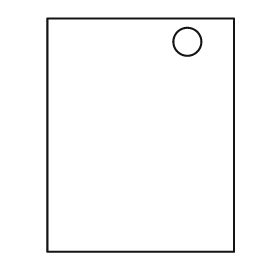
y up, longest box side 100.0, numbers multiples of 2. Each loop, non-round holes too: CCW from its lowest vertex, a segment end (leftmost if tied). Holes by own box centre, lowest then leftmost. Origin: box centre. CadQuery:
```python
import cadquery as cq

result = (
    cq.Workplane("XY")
    .moveTo(-40.0, -50.0)
    .lineTo(40.0, -50.0)
    .lineTo(40.0, 50.0)
    .lineTo(-40.0, 50.0)
    .close()
    .moveTo(20.0, 40.0)
    .circle(6.0)
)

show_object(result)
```